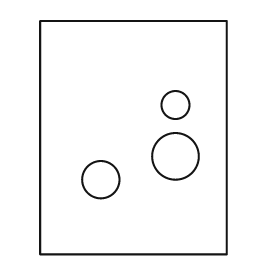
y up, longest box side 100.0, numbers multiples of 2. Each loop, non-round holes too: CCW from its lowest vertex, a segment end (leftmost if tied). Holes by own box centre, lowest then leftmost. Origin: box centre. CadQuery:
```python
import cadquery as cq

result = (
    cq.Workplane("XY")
    .moveTo(-40.0, -50.0)
    .lineTo(40.0, -50.0)
    .lineTo(40.0, 50.0)
    .lineTo(-40.0, 50.0)
    .close()
    .moveTo(-14.0, -18.0)
    .circle(8.0)
    .moveTo(18.0, -8.0)
    .circle(10.0)
    .moveTo(18.0, 14.0)
    .circle(6.0)
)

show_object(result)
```